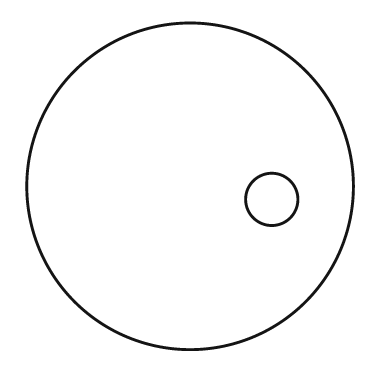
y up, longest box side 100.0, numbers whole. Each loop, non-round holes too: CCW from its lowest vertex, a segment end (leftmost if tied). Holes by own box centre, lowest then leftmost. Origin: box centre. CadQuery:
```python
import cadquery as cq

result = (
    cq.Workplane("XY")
    .moveTo(0.0, 0.0)
    .circle(50.0)
    .moveTo(25.0, -4.0)
    .circle(8.0)
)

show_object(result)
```